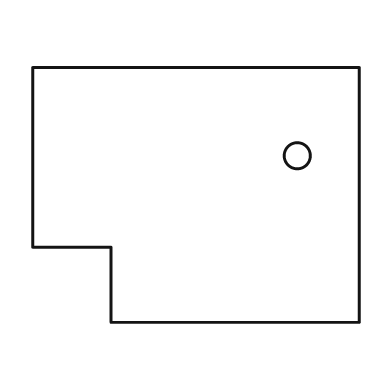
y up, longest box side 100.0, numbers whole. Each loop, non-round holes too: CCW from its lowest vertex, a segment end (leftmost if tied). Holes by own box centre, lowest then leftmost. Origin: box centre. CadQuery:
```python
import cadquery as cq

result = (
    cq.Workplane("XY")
    .moveTo(-26.0, -39.0)
    .lineTo(50.0, -39.0)
    .lineTo(50.0, 39.0)
    .lineTo(-50.0, 39.0)
    .lineTo(-50.0, -16.0)
    .lineTo(-26.0, -16.0)
    .close()
    .moveTo(31.0, 12.0)
    .circle(4.0)
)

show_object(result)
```